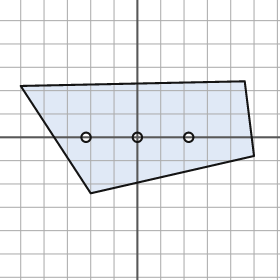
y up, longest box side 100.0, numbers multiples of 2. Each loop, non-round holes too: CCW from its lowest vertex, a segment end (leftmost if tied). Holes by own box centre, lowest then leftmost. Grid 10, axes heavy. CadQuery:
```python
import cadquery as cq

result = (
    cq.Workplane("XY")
    .moveTo(-20.0, -24.0)
    .lineTo(50.0, -8.0)
    .lineTo(46.0, 24.0)
    .lineTo(-50.0, 22.0)
    .close()
    .moveTo(-22.0, 0.0)
    .circle(2.0)
    .moveTo(0.0, 0.0)
    .circle(2.0)
    .moveTo(22.0, 0.0)
    .circle(2.0)
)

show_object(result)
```